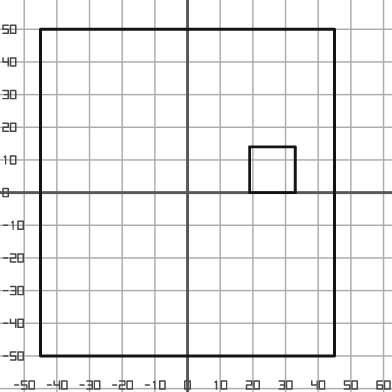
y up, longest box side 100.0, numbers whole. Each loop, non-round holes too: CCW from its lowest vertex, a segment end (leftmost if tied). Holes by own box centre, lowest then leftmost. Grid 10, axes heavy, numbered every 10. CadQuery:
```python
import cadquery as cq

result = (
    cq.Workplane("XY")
    .moveTo(-45.0, -50.0)
    .lineTo(45.0, -50.0)
    .lineTo(45.0, 50.0)
    .lineTo(-45.0, 50.0)
    .close()
    .moveTo(19.0, 0.0)
    .lineTo(33.0, 0.0)
    .lineTo(33.0, 14.0)
    .lineTo(19.0, 14.0)
    .close()
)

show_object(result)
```